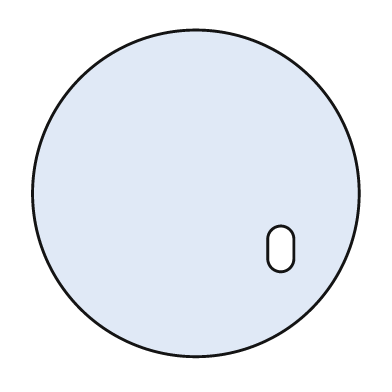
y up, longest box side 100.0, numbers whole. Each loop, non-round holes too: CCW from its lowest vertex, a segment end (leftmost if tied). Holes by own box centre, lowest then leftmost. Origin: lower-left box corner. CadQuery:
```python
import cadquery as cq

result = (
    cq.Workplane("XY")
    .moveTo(50.0, 50.0)
    .circle(50.0)
    .moveTo(72.0, 30.0)
    .threePointArc((76.0, 26.0), (80.0, 30.0))
    .lineTo(80.0, 36.0)
    .threePointArc((76.0, 40.0), (72.0, 36.0))
    .close()
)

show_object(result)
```